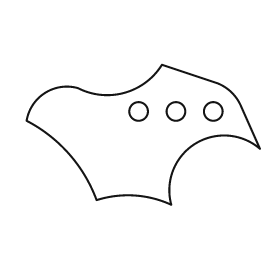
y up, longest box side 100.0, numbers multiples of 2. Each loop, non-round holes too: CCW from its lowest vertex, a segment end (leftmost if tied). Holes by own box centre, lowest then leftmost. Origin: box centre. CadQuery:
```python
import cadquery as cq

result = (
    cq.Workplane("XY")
    .moveTo(12.0, -30.0)
    .threePointArc((22.0, -4.0), (50.0, -6.0))
    .lineTo(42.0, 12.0)
    .threePointArc((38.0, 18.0), (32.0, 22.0))
    .lineTo(8.0, 30.0)
    .threePointArc((-8.0, 18.0), (-28.0, 20.0))
    .threePointArc((-42.0, 18.0), (-50.0, 6.0))
    .threePointArc((-32.0, -8.0), (-20.0, -28.0))
    .threePointArc((-4.0, -26.0), (12.0, -30.0))
    .close()
    .moveTo(-2.0, 10.0)
    .circle(4.0)
    .moveTo(14.0, 10.0)
    .circle(4.0)
    .moveTo(30.0, 10.0)
    .circle(4.0)
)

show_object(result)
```